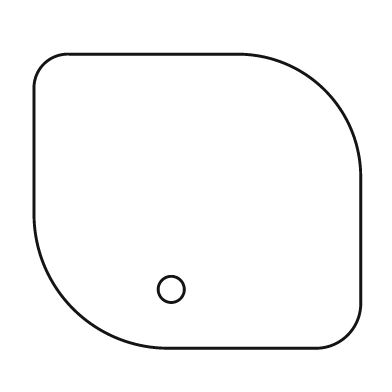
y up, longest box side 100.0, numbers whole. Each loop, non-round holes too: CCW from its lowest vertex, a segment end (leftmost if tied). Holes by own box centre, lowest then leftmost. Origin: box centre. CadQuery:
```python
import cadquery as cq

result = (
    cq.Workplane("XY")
    .moveTo(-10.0, -45.0)
    .lineTo(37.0, -45.0)
    .threePointArc((46.0, -41.0), (50.0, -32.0))
    .lineTo(50.0, 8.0)
    .threePointArc((39.0, 34.0), (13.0, 45.0))
    .lineTo(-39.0, 45.0)
    .threePointArc((-47.0, 42.0), (-50.0, 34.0))
    .lineTo(-50.0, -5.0)
    .threePointArc((-38.0, -33.0), (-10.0, -45.0))
    .close()
    .moveTo(-8.0, -27.0)
    .circle(4.0)
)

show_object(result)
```